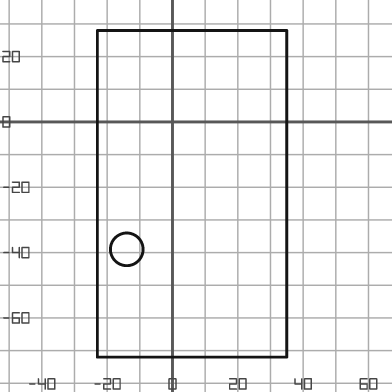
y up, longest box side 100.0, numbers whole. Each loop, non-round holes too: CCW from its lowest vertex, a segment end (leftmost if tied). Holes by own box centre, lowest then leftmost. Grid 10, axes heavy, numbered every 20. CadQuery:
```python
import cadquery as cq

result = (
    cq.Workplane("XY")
    .moveTo(-23.0, -72.0)
    .lineTo(35.0, -72.0)
    .lineTo(35.0, 28.0)
    .lineTo(-23.0, 28.0)
    .close()
    .moveTo(-14.0, -39.0)
    .circle(5.0)
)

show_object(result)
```